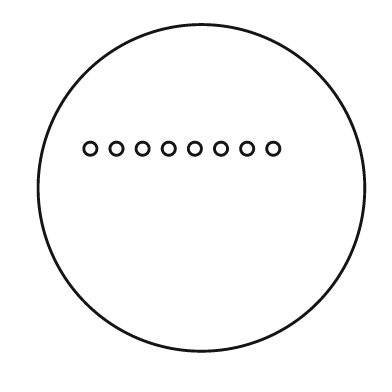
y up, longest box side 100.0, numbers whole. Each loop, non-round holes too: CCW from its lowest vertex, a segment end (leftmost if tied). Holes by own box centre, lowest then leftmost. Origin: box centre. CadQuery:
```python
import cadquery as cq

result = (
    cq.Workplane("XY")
    .moveTo(0.0, 0.0)
    .circle(50.0)
    .moveTo(-34.0, 12.0)
    .circle(2.0)
    .moveTo(-26.0, 12.0)
    .circle(2.0)
    .moveTo(-18.0, 12.0)
    .circle(2.0)
    .moveTo(-10.0, 12.0)
    .circle(2.0)
    .moveTo(-2.0, 12.0)
    .circle(2.0)
    .moveTo(6.0, 12.0)
    .circle(2.0)
    .moveTo(14.0, 12.0)
    .circle(2.0)
    .moveTo(22.0, 12.0)
    .circle(2.0)
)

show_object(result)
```